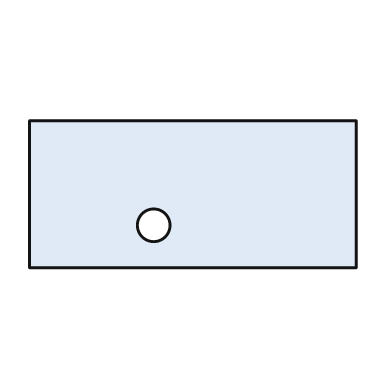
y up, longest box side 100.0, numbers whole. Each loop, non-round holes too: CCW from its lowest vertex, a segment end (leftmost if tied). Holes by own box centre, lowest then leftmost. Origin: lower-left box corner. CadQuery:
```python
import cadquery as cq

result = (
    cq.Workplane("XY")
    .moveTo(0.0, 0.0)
    .lineTo(100.0, 0.0)
    .lineTo(100.0, 45.0)
    .lineTo(0.0, 45.0)
    .close()
    .moveTo(38.0, 13.0)
    .circle(5.0)
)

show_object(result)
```